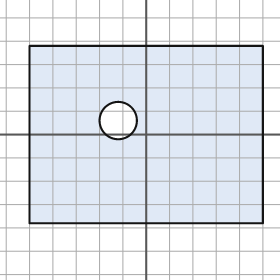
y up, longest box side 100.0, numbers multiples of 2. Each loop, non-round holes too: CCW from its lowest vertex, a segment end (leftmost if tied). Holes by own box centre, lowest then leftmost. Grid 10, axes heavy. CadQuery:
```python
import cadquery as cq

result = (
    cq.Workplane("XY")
    .moveTo(-50.0, -38.0)
    .lineTo(50.0, -38.0)
    .lineTo(50.0, 38.0)
    .lineTo(-50.0, 38.0)
    .close()
    .moveTo(-12.0, 6.0)
    .circle(8.0)
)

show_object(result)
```